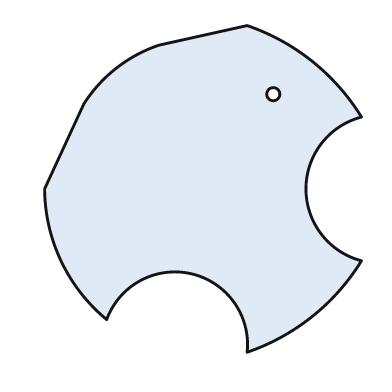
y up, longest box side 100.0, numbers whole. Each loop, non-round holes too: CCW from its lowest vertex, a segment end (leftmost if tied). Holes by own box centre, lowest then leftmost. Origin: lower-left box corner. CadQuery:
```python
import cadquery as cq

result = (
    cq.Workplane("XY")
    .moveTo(62.0, 0.0)
    .threePointArc((82.0, 11.0), (97.0, 28.0))
    .threePointArc((80.0, 50.0), (97.0, 72.0))
    .threePointArc((82.0, 89.0), (62.0, 100.0))
    .lineTo(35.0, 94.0)
    .threePointArc((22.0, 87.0), (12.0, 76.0))
    .lineTo(0.0, 50.0)
    .threePointArc((5.0, 28.0), (19.0, 10.0))
    .threePointArc((45.0, 24.0), (62.0, 0.0))
    .close()
    .moveTo(70.0, 79.0)
    .circle(2.0)
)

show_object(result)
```